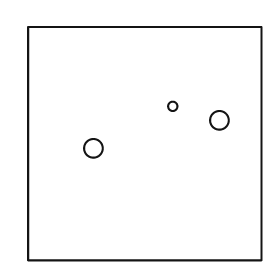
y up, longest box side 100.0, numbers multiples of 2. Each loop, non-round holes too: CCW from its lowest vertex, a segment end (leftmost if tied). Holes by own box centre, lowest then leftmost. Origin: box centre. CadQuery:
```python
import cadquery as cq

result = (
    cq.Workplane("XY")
    .moveTo(-50.0, -50.0)
    .lineTo(50.0, -50.0)
    .lineTo(50.0, 50.0)
    .lineTo(-50.0, 50.0)
    .close()
    .moveTo(-22.0, -2.0)
    .circle(4.0)
    .moveTo(32.0, 10.0)
    .circle(4.0)
    .moveTo(12.0, 16.0)
    .circle(2.0)
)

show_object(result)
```